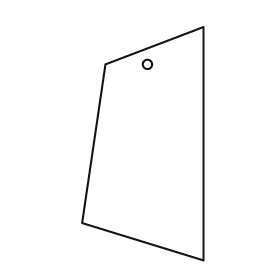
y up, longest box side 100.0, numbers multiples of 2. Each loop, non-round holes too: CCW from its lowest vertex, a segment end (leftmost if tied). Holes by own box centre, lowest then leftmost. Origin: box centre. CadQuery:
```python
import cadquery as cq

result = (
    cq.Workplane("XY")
    .moveTo(26.0, -50.0)
    .lineTo(26.0, 50.0)
    .lineTo(-16.0, 34.0)
    .lineTo(-26.0, -34.0)
    .close()
    .moveTo(2.0, 34.0)
    .circle(2.0)
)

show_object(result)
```